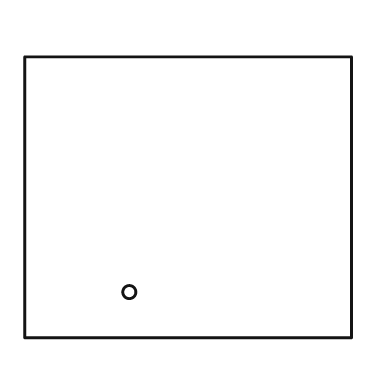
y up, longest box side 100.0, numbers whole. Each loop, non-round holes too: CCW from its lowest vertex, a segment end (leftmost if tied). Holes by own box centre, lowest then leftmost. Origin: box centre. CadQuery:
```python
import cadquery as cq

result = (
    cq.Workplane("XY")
    .moveTo(-50.0, -43.0)
    .lineTo(50.0, -43.0)
    .lineTo(50.0, 43.0)
    .lineTo(-50.0, 43.0)
    .close()
    .moveTo(-18.0, -29.0)
    .circle(2.0)
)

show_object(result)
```